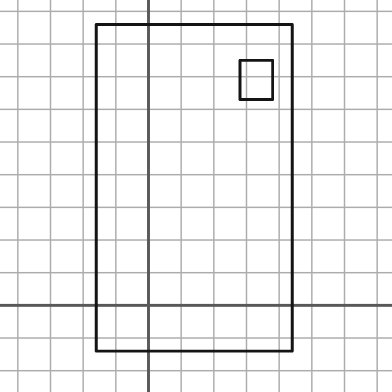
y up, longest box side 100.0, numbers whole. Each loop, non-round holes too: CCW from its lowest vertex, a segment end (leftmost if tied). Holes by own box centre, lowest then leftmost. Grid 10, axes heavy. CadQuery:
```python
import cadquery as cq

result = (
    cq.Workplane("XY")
    .moveTo(-16.0, -14.0)
    .lineTo(44.0, -14.0)
    .lineTo(44.0, 86.0)
    .lineTo(-16.0, 86.0)
    .close()
    .moveTo(28.0, 63.0)
    .lineTo(38.0, 63.0)
    .lineTo(38.0, 75.0)
    .lineTo(28.0, 75.0)
    .close()
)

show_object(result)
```